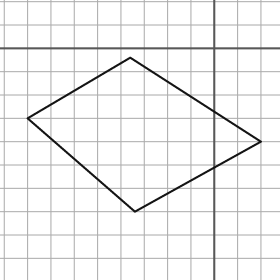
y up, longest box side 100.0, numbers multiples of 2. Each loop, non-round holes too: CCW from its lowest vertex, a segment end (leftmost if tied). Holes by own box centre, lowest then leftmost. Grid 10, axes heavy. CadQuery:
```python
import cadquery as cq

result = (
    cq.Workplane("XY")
    .moveTo(-34.0, -70.0)
    .lineTo(20.0, -40.0)
    .lineTo(-36.0, -4.0)
    .lineTo(-80.0, -30.0)
    .close()
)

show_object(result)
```